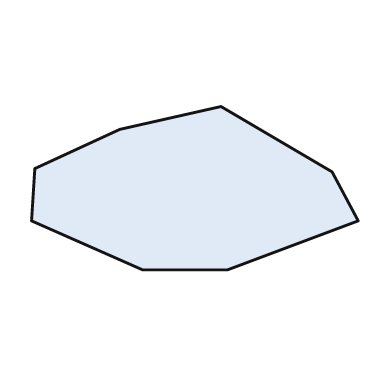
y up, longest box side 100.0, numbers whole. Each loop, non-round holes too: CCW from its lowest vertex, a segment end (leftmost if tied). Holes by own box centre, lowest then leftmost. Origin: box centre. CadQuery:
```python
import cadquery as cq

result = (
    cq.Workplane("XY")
    .moveTo(-16.0, -25.0)
    .lineTo(10.0, -25.0)
    .lineTo(50.0, -10.0)
    .lineTo(42.0, 5.0)
    .lineTo(8.0, 25.0)
    .lineTo(-23.0, 18.0)
    .lineTo(-49.0, 6.0)
    .lineTo(-50.0, -10.0)
    .close()
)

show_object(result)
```